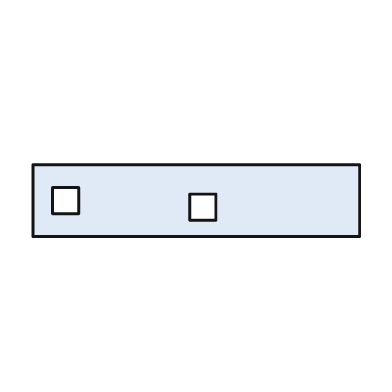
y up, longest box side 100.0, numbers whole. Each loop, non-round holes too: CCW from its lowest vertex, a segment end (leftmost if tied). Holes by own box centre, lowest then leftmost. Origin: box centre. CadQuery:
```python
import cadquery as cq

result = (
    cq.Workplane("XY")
    .moveTo(-50.0, -11.0)
    .lineTo(50.0, -11.0)
    .lineTo(50.0, 11.0)
    .lineTo(-50.0, 11.0)
    .close()
    .moveTo(-2.0, -6.0)
    .lineTo(6.0, -6.0)
    .lineTo(6.0, 2.0)
    .lineTo(-2.0, 2.0)
    .close()
    .moveTo(-44.0, -4.0)
    .lineTo(-36.0, -4.0)
    .lineTo(-36.0, 4.0)
    .lineTo(-44.0, 4.0)
    .close()
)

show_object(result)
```